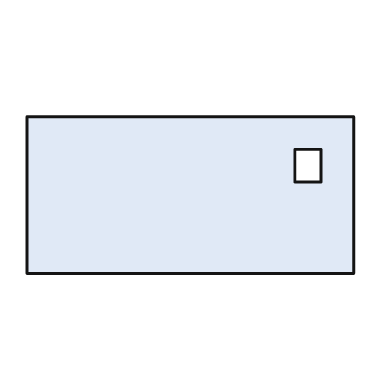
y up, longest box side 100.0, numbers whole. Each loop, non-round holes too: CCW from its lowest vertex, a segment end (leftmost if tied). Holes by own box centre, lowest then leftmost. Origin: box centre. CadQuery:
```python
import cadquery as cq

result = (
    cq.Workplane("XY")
    .moveTo(-50.0, -24.0)
    .lineTo(50.0, -24.0)
    .lineTo(50.0, 24.0)
    .lineTo(-50.0, 24.0)
    .close()
    .moveTo(32.0, 4.0)
    .lineTo(40.0, 4.0)
    .lineTo(40.0, 14.0)
    .lineTo(32.0, 14.0)
    .close()
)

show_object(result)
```